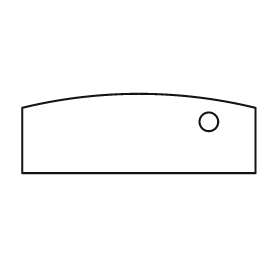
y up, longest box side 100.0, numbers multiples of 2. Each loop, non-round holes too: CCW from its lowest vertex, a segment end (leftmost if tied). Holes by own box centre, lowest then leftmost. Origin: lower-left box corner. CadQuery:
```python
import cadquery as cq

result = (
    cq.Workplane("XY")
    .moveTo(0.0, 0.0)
    .lineTo(100.0, 0.0)
    .lineTo(100.0, 28.0)
    .threePointArc((50.0, 34.0), (0.0, 28.0))
    .close()
    .moveTo(80.0, 22.0)
    .circle(4.0)
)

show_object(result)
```